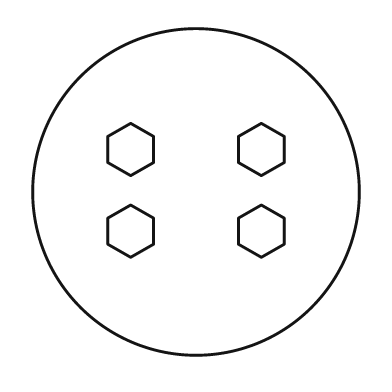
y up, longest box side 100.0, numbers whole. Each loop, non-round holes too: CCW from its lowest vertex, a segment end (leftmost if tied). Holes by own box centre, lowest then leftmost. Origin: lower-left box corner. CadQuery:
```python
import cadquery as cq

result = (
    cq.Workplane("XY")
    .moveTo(50.0, 50.0)
    .circle(50.0)
    .moveTo(30.0, 30.0)
    .lineTo(37.0, 34.0)
    .lineTo(37.0, 42.0)
    .lineTo(30.0, 46.0)
    .lineTo(23.0, 42.0)
    .lineTo(23.0, 34.0)
    .close()
    .moveTo(70.0, 30.0)
    .lineTo(77.0, 34.0)
    .lineTo(77.0, 42.0)
    .lineTo(70.0, 46.0)
    .lineTo(63.0, 42.0)
    .lineTo(63.0, 34.0)
    .close()
    .moveTo(30.0, 55.0)
    .lineTo(37.0, 59.0)
    .lineTo(37.0, 67.0)
    .lineTo(30.0, 71.0)
    .lineTo(23.0, 67.0)
    .lineTo(23.0, 59.0)
    .close()
    .moveTo(70.0, 55.0)
    .lineTo(77.0, 59.0)
    .lineTo(77.0, 67.0)
    .lineTo(70.0, 71.0)
    .lineTo(63.0, 67.0)
    .lineTo(63.0, 59.0)
    .close()
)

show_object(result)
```